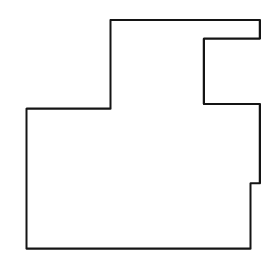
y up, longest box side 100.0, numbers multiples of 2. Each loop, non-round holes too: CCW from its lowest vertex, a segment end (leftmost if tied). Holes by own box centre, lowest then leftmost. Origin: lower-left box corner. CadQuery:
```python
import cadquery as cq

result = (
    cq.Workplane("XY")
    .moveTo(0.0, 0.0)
    .lineTo(96.0, 0.0)
    .lineTo(96.0, 28.0)
    .lineTo(100.0, 28.0)
    .lineTo(100.0, 62.0)
    .lineTo(76.0, 62.0)
    .lineTo(76.0, 90.0)
    .lineTo(100.0, 90.0)
    .lineTo(100.0, 98.0)
    .lineTo(36.0, 98.0)
    .lineTo(36.0, 60.0)
    .lineTo(0.0, 60.0)
    .close()
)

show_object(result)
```